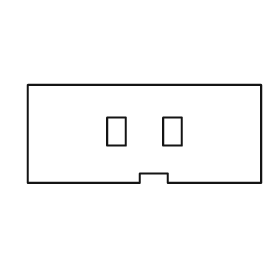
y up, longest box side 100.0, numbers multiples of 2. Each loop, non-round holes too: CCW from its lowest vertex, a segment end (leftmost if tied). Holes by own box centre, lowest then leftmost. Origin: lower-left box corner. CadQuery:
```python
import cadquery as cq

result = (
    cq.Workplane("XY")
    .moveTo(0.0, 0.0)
    .lineTo(48.0, 0.0)
    .lineTo(48.0, 4.0)
    .lineTo(60.0, 4.0)
    .lineTo(60.0, 0.0)
    .lineTo(100.0, 0.0)
    .lineTo(100.0, 42.0)
    .lineTo(0.0, 42.0)
    .close()
    .moveTo(34.0, 16.0)
    .lineTo(42.0, 16.0)
    .lineTo(42.0, 28.0)
    .lineTo(34.0, 28.0)
    .close()
    .moveTo(58.0, 16.0)
    .lineTo(66.0, 16.0)
    .lineTo(66.0, 28.0)
    .lineTo(58.0, 28.0)
    .close()
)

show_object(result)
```